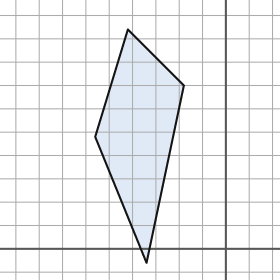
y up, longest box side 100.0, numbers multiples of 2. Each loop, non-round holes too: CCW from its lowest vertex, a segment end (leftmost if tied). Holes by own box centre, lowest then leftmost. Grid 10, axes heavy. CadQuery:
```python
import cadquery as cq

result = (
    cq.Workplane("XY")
    .moveTo(-34.0, -6.0)
    .lineTo(-18.0, 70.0)
    .lineTo(-42.0, 94.0)
    .lineTo(-56.0, 48.0)
    .close()
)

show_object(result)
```